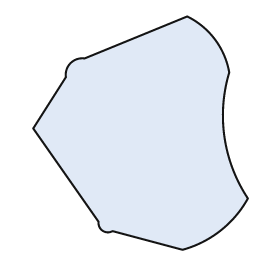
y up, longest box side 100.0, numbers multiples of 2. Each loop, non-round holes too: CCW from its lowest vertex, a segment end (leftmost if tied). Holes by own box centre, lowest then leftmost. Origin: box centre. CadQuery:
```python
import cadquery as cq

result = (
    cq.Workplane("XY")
    .moveTo(18.0, -50.0)
    .threePointArc((34.0, -42.0), (46.0, -28.0))
    .threePointArc((36.0, -2.0), (38.0, 26.0))
    .threePointArc((32.0, 40.0), (20.0, 50.0))
    .lineTo(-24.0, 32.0)
    .threePointArc((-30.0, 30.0), (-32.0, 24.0))
    .lineTo(-46.0, 2.0)
    .lineTo(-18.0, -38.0)
    .threePointArc((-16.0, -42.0), (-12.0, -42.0))
    .close()
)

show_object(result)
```